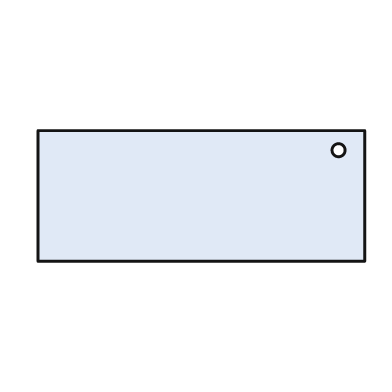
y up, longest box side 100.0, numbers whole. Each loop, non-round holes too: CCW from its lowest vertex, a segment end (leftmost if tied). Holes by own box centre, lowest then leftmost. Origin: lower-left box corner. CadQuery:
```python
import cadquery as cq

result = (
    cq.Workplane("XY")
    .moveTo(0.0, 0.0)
    .lineTo(100.0, 0.0)
    .lineTo(100.0, 40.0)
    .lineTo(0.0, 40.0)
    .close()
    .moveTo(92.0, 34.0)
    .circle(2.0)
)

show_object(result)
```